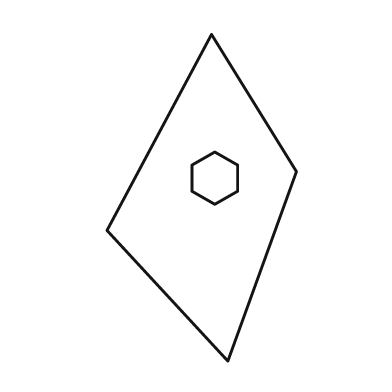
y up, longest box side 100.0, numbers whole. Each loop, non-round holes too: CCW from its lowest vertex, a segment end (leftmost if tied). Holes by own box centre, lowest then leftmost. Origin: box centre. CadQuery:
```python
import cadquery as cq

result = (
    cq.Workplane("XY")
    .moveTo(8.0, -50.0)
    .lineTo(29.0, 8.0)
    .lineTo(3.0, 50.0)
    .lineTo(-29.0, -10.0)
    .close()
    .moveTo(4.0, -2.0)
    .lineTo(11.0, 2.0)
    .lineTo(11.0, 10.0)
    .lineTo(4.0, 14.0)
    .lineTo(-3.0, 10.0)
    .lineTo(-3.0, 2.0)
    .close()
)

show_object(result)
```